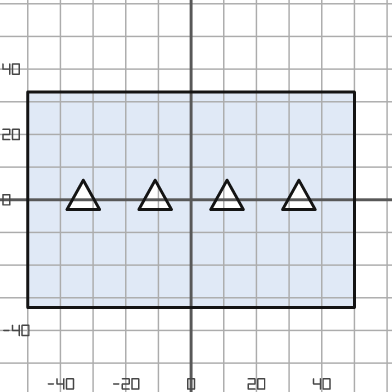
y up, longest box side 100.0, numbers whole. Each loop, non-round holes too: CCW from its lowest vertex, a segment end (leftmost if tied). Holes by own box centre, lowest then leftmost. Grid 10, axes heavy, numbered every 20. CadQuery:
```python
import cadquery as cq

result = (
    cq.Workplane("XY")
    .moveTo(-50.0, -33.0)
    .lineTo(50.0, -33.0)
    .lineTo(50.0, 33.0)
    .lineTo(-50.0, 33.0)
    .close()
    .moveTo(-38.0, -3.0)
    .lineTo(-28.0, -3.0)
    .lineTo(-33.0, 6.0)
    .close()
    .moveTo(-16.0, -3.0)
    .lineTo(-6.0, -3.0)
    .lineTo(-11.0, 6.0)
    .close()
    .moveTo(6.0, -3.0)
    .lineTo(16.0, -3.0)
    .lineTo(11.0, 6.0)
    .close()
    .moveTo(28.0, -3.0)
    .lineTo(38.0, -3.0)
    .lineTo(33.0, 6.0)
    .close()
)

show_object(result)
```